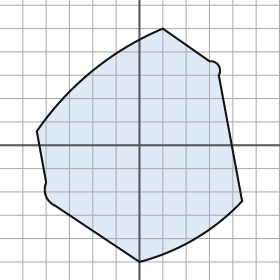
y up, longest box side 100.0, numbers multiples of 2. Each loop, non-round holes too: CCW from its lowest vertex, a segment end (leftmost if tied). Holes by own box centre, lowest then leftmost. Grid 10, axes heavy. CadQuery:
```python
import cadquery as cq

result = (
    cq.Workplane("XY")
    .moveTo(0.0, -50.0)
    .threePointArc((24.0, -40.0), (44.0, -24.0))
    .lineTo(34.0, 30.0)
    .threePointArc((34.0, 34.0), (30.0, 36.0))
    .lineTo(10.0, 50.0)
    .threePointArc((-20.0, 32.0), (-44.0, 6.0))
    .lineTo(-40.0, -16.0)
    .threePointArc((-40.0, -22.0), (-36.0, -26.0))
    .close()
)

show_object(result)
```